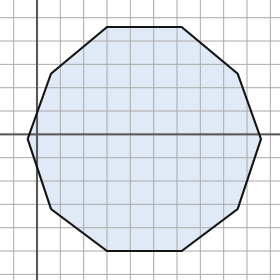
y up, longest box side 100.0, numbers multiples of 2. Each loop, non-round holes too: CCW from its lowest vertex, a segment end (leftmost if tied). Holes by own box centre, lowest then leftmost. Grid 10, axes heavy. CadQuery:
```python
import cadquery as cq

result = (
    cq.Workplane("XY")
    .moveTo(30.0, -50.0)
    .lineTo(62.0, -50.0)
    .lineTo(86.0, -32.0)
    .lineTo(96.0, -2.0)
    .lineTo(86.0, 26.0)
    .lineTo(62.0, 46.0)
    .lineTo(30.0, 46.0)
    .lineTo(6.0, 26.0)
    .lineTo(-4.0, -2.0)
    .lineTo(6.0, -32.0)
    .close()
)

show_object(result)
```